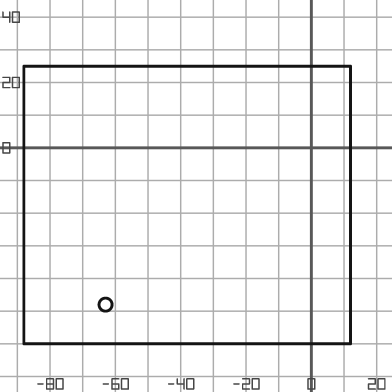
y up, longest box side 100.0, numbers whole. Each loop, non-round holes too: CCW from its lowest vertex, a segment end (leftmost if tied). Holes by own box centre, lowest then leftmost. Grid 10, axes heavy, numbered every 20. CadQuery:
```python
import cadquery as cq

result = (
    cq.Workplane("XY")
    .moveTo(-88.0, -60.0)
    .lineTo(12.0, -60.0)
    .lineTo(12.0, 25.0)
    .lineTo(-88.0, 25.0)
    .close()
    .moveTo(-63.0, -48.0)
    .circle(2.0)
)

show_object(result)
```